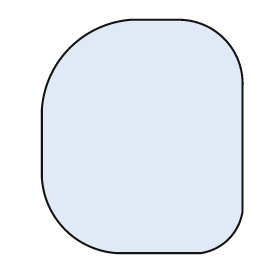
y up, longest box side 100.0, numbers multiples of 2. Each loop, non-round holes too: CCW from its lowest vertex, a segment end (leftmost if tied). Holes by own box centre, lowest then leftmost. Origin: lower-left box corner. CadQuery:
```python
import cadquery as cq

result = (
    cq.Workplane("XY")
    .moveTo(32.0, 0.0)
    .lineTo(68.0, 0.0)
    .threePointArc((80.0, 6.0), (86.0, 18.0))
    .lineTo(86.0, 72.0)
    .threePointArc((78.0, 92.0), (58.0, 100.0))
    .lineTo(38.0, 100.0)
    .threePointArc((12.0, 88.0), (0.0, 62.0))
    .lineTo(0.0, 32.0)
    .threePointArc((10.0, 10.0), (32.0, 0.0))
    .close()
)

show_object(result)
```